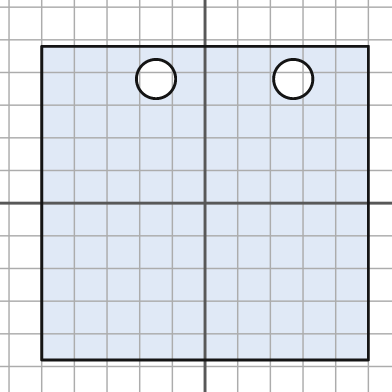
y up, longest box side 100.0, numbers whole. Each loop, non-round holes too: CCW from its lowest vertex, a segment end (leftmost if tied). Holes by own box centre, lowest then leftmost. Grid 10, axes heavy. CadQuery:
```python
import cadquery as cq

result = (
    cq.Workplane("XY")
    .moveTo(-50.0, -48.0)
    .lineTo(50.0, -48.0)
    .lineTo(50.0, 48.0)
    .lineTo(-50.0, 48.0)
    .close()
    .moveTo(-15.0, 38.0)
    .circle(6.0)
    .moveTo(27.0, 38.0)
    .circle(6.0)
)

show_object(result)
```